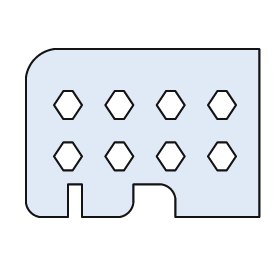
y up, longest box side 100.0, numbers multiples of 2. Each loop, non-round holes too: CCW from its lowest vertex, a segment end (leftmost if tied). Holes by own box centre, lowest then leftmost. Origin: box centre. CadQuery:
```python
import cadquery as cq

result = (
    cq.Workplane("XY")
    .moveTo(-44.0, -36.0)
    .lineTo(-32.0, -36.0)
    .lineTo(-32.0, -22.0)
    .lineTo(-26.0, -22.0)
    .lineTo(-26.0, -36.0)
    .lineTo(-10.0, -36.0)
    .threePointArc((-6.0, -34.0), (-4.0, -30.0))
    .lineTo(-4.0, -22.0)
    .lineTo(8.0, -22.0)
    .threePointArc((12.0, -24.0), (14.0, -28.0))
    .lineTo(14.0, -36.0)
    .lineTo(50.0, -36.0)
    .lineTo(50.0, 36.0)
    .lineTo(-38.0, 36.0)
    .threePointArc((-46.0, 32.0), (-50.0, 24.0))
    .lineTo(-50.0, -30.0)
    .threePointArc((-48.0, -34.0), (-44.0, -36.0))
    .close()
    .moveTo(-34.0, -16.0)
    .lineTo(-30.0, -16.0)
    .lineTo(-26.0, -10.0)
    .lineTo(-30.0, -4.0)
    .lineTo(-34.0, -4.0)
    .lineTo(-38.0, -10.0)
    .close()
    .moveTo(-12.0, -16.0)
    .lineTo(-8.0, -16.0)
    .lineTo(-4.0, -10.0)
    .lineTo(-8.0, -4.0)
    .lineTo(-12.0, -4.0)
    .lineTo(-16.0, -10.0)
    .close()
    .moveTo(10.0, -16.0)
    .lineTo(14.0, -16.0)
    .lineTo(18.0, -10.0)
    .lineTo(14.0, -4.0)
    .lineTo(10.0, -4.0)
    .lineTo(6.0, -10.0)
    .close()
    .moveTo(32.0, -16.0)
    .lineTo(36.0, -16.0)
    .lineTo(40.0, -10.0)
    .lineTo(36.0, -4.0)
    .lineTo(32.0, -4.0)
    .lineTo(28.0, -10.0)
    .close()
    .moveTo(-34.0, 6.0)
    .lineTo(-30.0, 6.0)
    .lineTo(-26.0, 12.0)
    .lineTo(-30.0, 18.0)
    .lineTo(-34.0, 18.0)
    .lineTo(-38.0, 12.0)
    .close()
    .moveTo(-12.0, 6.0)
    .lineTo(-8.0, 6.0)
    .lineTo(-4.0, 12.0)
    .lineTo(-8.0, 18.0)
    .lineTo(-12.0, 18.0)
    .lineTo(-16.0, 12.0)
    .close()
    .moveTo(10.0, 6.0)
    .lineTo(14.0, 6.0)
    .lineTo(18.0, 12.0)
    .lineTo(14.0, 18.0)
    .lineTo(10.0, 18.0)
    .lineTo(6.0, 12.0)
    .close()
    .moveTo(32.0, 6.0)
    .lineTo(36.0, 6.0)
    .lineTo(40.0, 12.0)
    .lineTo(36.0, 18.0)
    .lineTo(32.0, 18.0)
    .lineTo(28.0, 12.0)
    .close()
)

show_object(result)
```